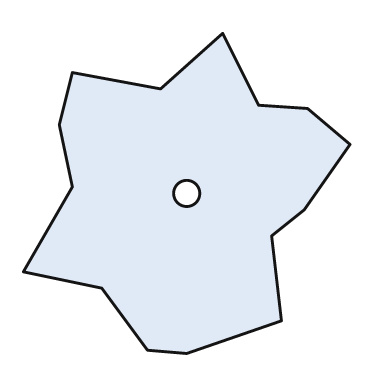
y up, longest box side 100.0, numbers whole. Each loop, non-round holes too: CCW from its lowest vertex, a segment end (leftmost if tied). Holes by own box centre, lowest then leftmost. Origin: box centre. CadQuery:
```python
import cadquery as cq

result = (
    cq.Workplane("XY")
    .moveTo(0.0, -49.0)
    .lineTo(29.0, -39.0)
    .lineTo(26.0, -13.0)
    .lineTo(36.0, -5.0)
    .lineTo(50.0, 15.0)
    .lineTo(37.0, 26.0)
    .lineTo(22.0, 27.0)
    .lineTo(11.0, 49.0)
    .lineTo(-8.0, 32.0)
    .lineTo(-35.0, 37.0)
    .lineTo(-39.0, 21.0)
    .lineTo(-35.0, 2.0)
    .lineTo(-50.0, -24.0)
    .lineTo(-26.0, -29.0)
    .lineTo(-12.0, -48.0)
    .close()
    .moveTo(0.0, 0.0)
    .circle(4.0)
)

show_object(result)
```